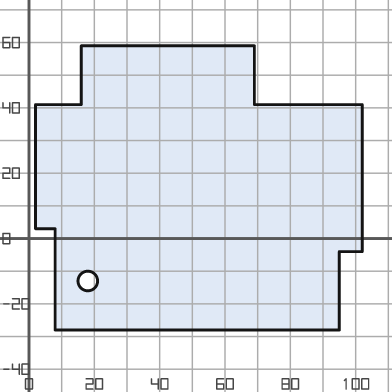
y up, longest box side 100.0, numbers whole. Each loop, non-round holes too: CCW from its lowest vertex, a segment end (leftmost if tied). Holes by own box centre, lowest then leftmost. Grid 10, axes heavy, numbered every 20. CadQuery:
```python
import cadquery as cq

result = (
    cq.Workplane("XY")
    .moveTo(8.0, -28.0)
    .lineTo(95.0, -28.0)
    .lineTo(95.0, -4.0)
    .lineTo(102.0, -4.0)
    .lineTo(102.0, 41.0)
    .lineTo(69.0, 41.0)
    .lineTo(69.0, 59.0)
    .lineTo(16.0, 59.0)
    .lineTo(16.0, 41.0)
    .lineTo(2.0, 41.0)
    .lineTo(2.0, 3.0)
    .lineTo(8.0, 3.0)
    .close()
    .moveTo(18.0, -13.0)
    .circle(3.0)
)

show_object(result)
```